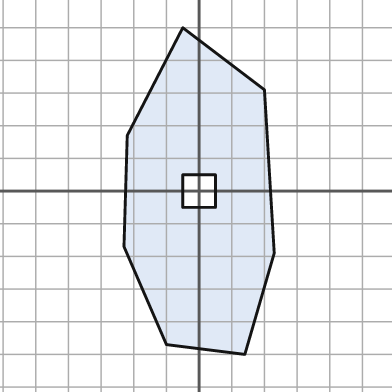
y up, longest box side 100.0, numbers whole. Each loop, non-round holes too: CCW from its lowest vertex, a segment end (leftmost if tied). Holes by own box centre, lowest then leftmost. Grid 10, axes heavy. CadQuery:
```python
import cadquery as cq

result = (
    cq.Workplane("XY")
    .moveTo(14.0, -50.0)
    .lineTo(23.0, -19.0)
    .lineTo(20.0, 31.0)
    .lineTo(-5.0, 50.0)
    .lineTo(-22.0, 17.0)
    .lineTo(-23.0, -17.0)
    .lineTo(-10.0, -47.0)
    .close()
    .moveTo(-5.0, -5.0)
    .lineTo(5.0, -5.0)
    .lineTo(5.0, 5.0)
    .lineTo(-5.0, 5.0)
    .close()
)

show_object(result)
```